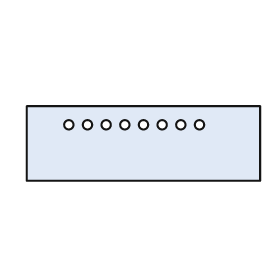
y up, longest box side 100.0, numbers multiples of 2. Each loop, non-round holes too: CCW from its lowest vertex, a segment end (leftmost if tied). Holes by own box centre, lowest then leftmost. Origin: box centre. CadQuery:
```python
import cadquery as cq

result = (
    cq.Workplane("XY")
    .moveTo(-50.0, -16.0)
    .lineTo(50.0, -16.0)
    .lineTo(50.0, 16.0)
    .lineTo(-50.0, 16.0)
    .close()
    .moveTo(-32.0, 8.0)
    .circle(2.0)
    .moveTo(-24.0, 8.0)
    .circle(2.0)
    .moveTo(-16.0, 8.0)
    .circle(2.0)
    .moveTo(-8.0, 8.0)
    .circle(2.0)
    .moveTo(0.0, 8.0)
    .circle(2.0)
    .moveTo(8.0, 8.0)
    .circle(2.0)
    .moveTo(16.0, 8.0)
    .circle(2.0)
    .moveTo(24.0, 8.0)
    .circle(2.0)
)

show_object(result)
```